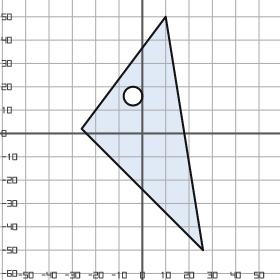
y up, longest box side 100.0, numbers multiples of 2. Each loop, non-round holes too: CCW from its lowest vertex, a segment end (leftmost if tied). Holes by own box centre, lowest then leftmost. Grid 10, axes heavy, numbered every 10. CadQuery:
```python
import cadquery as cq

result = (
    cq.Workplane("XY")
    .moveTo(26.0, -50.0)
    .lineTo(10.0, 50.0)
    .lineTo(-26.0, 2.0)
    .close()
    .moveTo(-4.0, 16.0)
    .circle(4.0)
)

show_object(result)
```